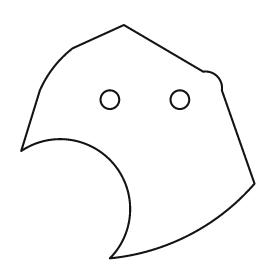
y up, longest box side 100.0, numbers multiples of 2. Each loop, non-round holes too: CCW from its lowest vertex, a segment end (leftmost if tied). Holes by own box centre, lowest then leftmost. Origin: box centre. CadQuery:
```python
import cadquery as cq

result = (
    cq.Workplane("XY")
    .moveTo(-12.0, -50.0)
    .threePointArc((22.0, -40.0), (50.0, -18.0))
    .lineTo(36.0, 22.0)
    .threePointArc((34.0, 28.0), (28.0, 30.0))
    .lineTo(-6.0, 50.0)
    .lineTo(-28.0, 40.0)
    .threePointArc((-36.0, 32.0), (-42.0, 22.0))
    .lineTo(-50.0, -4.0)
    .threePointArc((-10.0, -10.0), (-12.0, -50.0))
    .close()
    .moveTo(-12.0, 18.0)
    .circle(4.0)
    .moveTo(18.0, 18.0)
    .circle(4.0)
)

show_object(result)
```